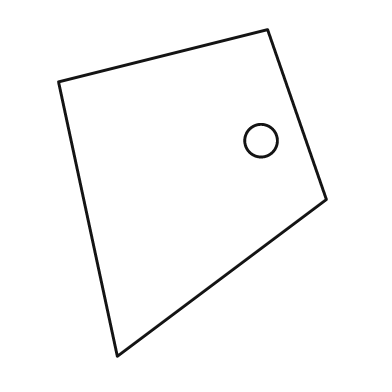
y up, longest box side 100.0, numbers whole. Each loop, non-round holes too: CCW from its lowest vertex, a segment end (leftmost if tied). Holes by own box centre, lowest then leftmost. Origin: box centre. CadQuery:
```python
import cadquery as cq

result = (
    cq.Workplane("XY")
    .moveTo(-23.0, -50.0)
    .lineTo(41.0, -2.0)
    .lineTo(23.0, 50.0)
    .lineTo(-41.0, 34.0)
    .close()
    .moveTo(21.0, 16.0)
    .circle(5.0)
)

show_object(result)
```